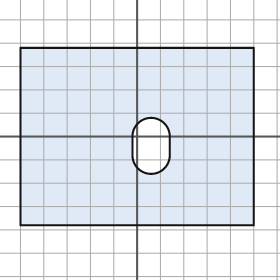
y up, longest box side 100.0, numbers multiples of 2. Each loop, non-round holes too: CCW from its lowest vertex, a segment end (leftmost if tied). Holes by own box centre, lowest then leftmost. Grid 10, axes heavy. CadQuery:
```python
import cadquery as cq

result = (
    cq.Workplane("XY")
    .moveTo(-50.0, -38.0)
    .lineTo(50.0, -38.0)
    .lineTo(50.0, 38.0)
    .lineTo(-50.0, 38.0)
    .close()
    .moveTo(-2.0, -8.0)
    .threePointArc((6.0, -16.0), (14.0, -8.0))
    .lineTo(14.0, 0.0)
    .threePointArc((6.0, 8.0), (-2.0, 0.0))
    .close()
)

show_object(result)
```